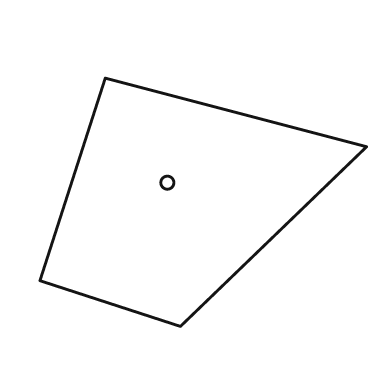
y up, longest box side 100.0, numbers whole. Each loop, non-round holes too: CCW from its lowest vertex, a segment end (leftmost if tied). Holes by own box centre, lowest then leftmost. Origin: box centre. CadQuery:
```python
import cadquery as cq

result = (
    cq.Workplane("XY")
    .moveTo(-7.0, -38.0)
    .lineTo(50.0, 17.0)
    .lineTo(-30.0, 38.0)
    .lineTo(-50.0, -24.0)
    .close()
    .moveTo(-11.0, 6.0)
    .circle(2.0)
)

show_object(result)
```